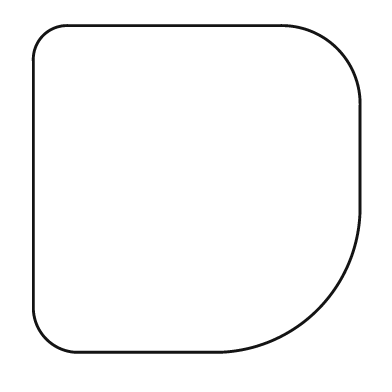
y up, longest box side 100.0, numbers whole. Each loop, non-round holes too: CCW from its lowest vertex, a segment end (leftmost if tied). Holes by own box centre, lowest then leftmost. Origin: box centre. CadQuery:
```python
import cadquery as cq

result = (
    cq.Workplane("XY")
    .moveTo(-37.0, -50.0)
    .lineTo(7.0, -50.0)
    .threePointArc((37.0, -37.0), (50.0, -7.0))
    .lineTo(50.0, 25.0)
    .threePointArc((43.0, 43.0), (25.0, 50.0))
    .lineTo(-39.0, 50.0)
    .threePointArc((-47.0, 47.0), (-50.0, 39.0))
    .lineTo(-50.0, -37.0)
    .threePointArc((-46.0, -46.0), (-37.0, -50.0))
    .close()
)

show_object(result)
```